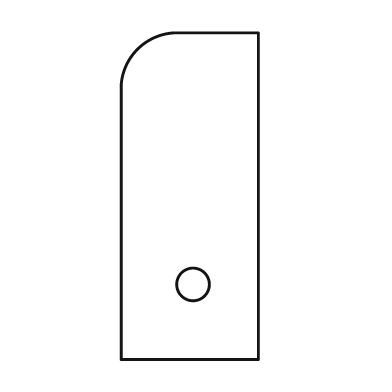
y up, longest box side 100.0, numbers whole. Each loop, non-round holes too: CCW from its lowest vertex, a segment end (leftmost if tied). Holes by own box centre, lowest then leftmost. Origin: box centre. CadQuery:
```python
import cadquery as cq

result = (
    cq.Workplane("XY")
    .moveTo(-21.0, -50.0)
    .lineTo(21.0, -50.0)
    .lineTo(21.0, 50.0)
    .lineTo(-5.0, 50.0)
    .threePointArc((-16.0, 45.0), (-21.0, 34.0))
    .close()
    .moveTo(1.0, -27.0)
    .circle(5.0)
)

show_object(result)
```